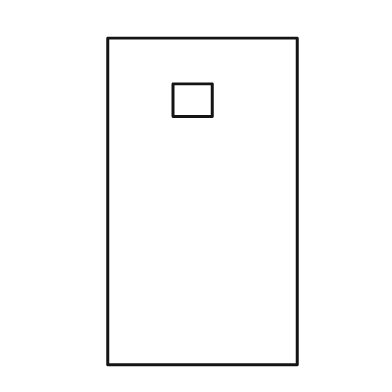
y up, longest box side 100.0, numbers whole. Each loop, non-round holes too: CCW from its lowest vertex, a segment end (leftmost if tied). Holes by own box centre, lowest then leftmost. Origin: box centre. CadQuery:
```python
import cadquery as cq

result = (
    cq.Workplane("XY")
    .moveTo(-29.0, -50.0)
    .lineTo(29.0, -50.0)
    .lineTo(29.0, 50.0)
    .lineTo(-29.0, 50.0)
    .close()
    .moveTo(-9.0, 26.0)
    .lineTo(3.0, 26.0)
    .lineTo(3.0, 36.0)
    .lineTo(-9.0, 36.0)
    .close()
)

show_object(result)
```